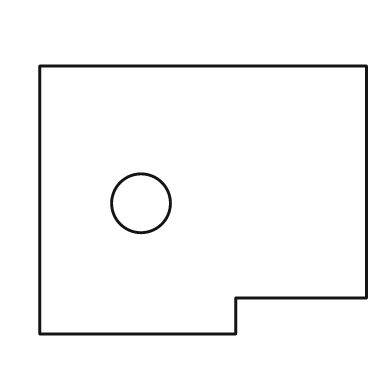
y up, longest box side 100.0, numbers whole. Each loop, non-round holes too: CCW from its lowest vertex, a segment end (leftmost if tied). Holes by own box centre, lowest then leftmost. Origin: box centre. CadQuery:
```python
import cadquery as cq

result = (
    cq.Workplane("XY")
    .moveTo(-50.0, -41.0)
    .lineTo(10.0, -41.0)
    .lineTo(10.0, -30.0)
    .lineTo(50.0, -30.0)
    .lineTo(50.0, 41.0)
    .lineTo(-50.0, 41.0)
    .close()
    .moveTo(-19.0, -1.0)
    .circle(9.0)
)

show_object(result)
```